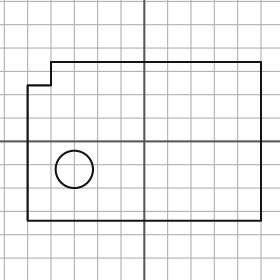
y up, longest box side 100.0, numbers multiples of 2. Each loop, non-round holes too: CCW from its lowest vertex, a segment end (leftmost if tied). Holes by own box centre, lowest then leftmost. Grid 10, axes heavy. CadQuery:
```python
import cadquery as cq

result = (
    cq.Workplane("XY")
    .moveTo(-50.0, -34.0)
    .lineTo(50.0, -34.0)
    .lineTo(50.0, 34.0)
    .lineTo(-40.0, 34.0)
    .lineTo(-40.0, 24.0)
    .lineTo(-50.0, 24.0)
    .close()
    .moveTo(-30.0, -12.0)
    .circle(8.0)
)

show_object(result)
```